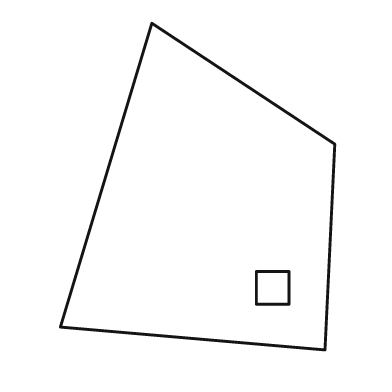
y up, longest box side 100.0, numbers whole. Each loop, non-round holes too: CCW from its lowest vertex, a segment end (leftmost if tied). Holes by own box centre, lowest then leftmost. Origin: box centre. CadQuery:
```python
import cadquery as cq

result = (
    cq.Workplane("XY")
    .moveTo(39.0, -50.0)
    .lineTo(42.0, 13.0)
    .lineTo(-14.0, 50.0)
    .lineTo(-42.0, -43.0)
    .close()
    .moveTo(18.0, -36.0)
    .lineTo(28.0, -36.0)
    .lineTo(28.0, -26.0)
    .lineTo(18.0, -26.0)
    .close()
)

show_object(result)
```